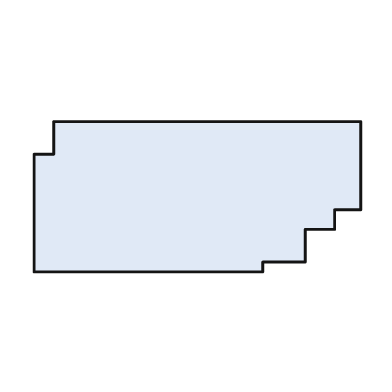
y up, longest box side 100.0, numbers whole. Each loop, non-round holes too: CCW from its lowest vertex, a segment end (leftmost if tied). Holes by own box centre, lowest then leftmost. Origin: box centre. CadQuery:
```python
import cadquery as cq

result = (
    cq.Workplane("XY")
    .moveTo(-50.0, -23.0)
    .lineTo(20.0, -23.0)
    .lineTo(20.0, -20.0)
    .lineTo(33.0, -20.0)
    .lineTo(33.0, -10.0)
    .lineTo(42.0, -10.0)
    .lineTo(42.0, -4.0)
    .lineTo(50.0, -4.0)
    .lineTo(50.0, 23.0)
    .lineTo(-44.0, 23.0)
    .lineTo(-44.0, 13.0)
    .lineTo(-50.0, 13.0)
    .close()
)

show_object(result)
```